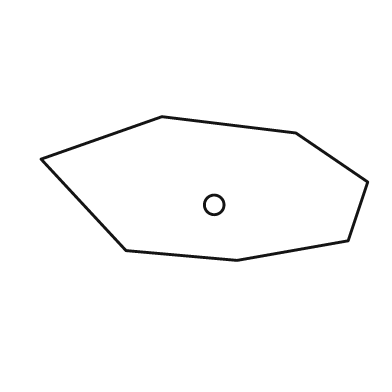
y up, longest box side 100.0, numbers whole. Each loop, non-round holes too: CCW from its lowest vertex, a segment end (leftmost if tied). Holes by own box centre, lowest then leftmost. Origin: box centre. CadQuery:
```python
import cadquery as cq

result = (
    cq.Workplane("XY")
    .moveTo(10.0, -22.0)
    .lineTo(44.0, -16.0)
    .lineTo(50.0, 2.0)
    .lineTo(28.0, 17.0)
    .lineTo(-13.0, 22.0)
    .lineTo(-50.0, 9.0)
    .lineTo(-24.0, -19.0)
    .close()
    .moveTo(3.0, -5.0)
    .circle(3.0)
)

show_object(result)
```